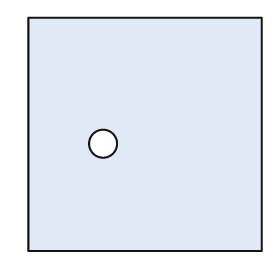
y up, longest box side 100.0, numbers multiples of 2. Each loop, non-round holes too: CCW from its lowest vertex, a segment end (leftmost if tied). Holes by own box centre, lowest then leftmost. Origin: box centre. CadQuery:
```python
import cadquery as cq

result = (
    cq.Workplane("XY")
    .moveTo(-50.0, -50.0)
    .lineTo(50.0, -50.0)
    .lineTo(50.0, 50.0)
    .lineTo(-50.0, 50.0)
    .close()
    .moveTo(-18.0, -4.0)
    .circle(6.0)
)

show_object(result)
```